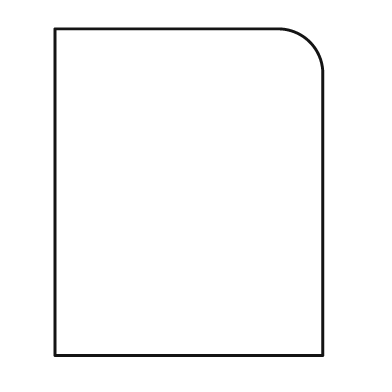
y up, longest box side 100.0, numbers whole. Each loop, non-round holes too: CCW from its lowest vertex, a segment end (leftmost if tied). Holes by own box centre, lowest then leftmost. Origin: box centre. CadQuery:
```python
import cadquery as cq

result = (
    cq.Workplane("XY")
    .moveTo(-41.0, -50.0)
    .lineTo(41.0, -50.0)
    .lineTo(41.0, 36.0)
    .threePointArc((37.0, 46.0), (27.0, 50.0))
    .lineTo(-41.0, 50.0)
    .close()
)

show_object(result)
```